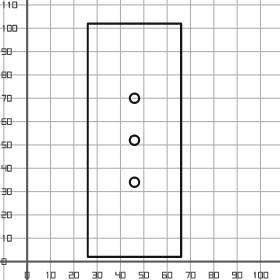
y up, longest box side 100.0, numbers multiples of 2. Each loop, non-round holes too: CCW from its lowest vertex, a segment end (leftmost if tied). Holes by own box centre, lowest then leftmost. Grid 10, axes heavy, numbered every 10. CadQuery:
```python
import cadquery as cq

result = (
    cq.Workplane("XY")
    .moveTo(26.0, 2.0)
    .lineTo(66.0, 2.0)
    .lineTo(66.0, 102.0)
    .lineTo(26.0, 102.0)
    .close()
    .moveTo(46.0, 34.0)
    .circle(2.0)
    .moveTo(46.0, 52.0)
    .circle(2.0)
    .moveTo(46.0, 70.0)
    .circle(2.0)
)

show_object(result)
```